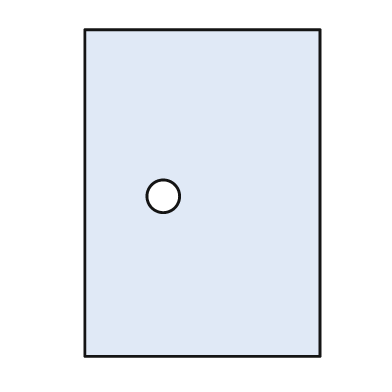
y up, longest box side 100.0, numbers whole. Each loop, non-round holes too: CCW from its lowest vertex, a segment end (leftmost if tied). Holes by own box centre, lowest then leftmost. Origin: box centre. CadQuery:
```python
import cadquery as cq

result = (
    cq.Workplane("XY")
    .moveTo(-36.0, -50.0)
    .lineTo(36.0, -50.0)
    .lineTo(36.0, 50.0)
    .lineTo(-36.0, 50.0)
    .close()
    .moveTo(-12.0, -1.0)
    .circle(5.0)
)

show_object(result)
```